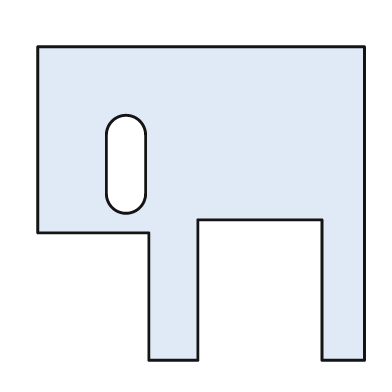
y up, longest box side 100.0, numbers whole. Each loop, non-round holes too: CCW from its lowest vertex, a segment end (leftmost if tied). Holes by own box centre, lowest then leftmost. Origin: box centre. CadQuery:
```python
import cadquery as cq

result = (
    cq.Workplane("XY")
    .moveTo(-16.0, -48.0)
    .lineTo(-1.0, -48.0)
    .lineTo(-1.0, -5.0)
    .lineTo(37.0, -5.0)
    .lineTo(37.0, -48.0)
    .lineTo(50.0, -48.0)
    .lineTo(50.0, 48.0)
    .lineTo(-50.0, 48.0)
    .lineTo(-50.0, -9.0)
    .lineTo(-16.0, -9.0)
    .close()
    .moveTo(-29.0, 3.0)
    .threePointArc((-23.0, -3.0), (-17.0, 3.0))
    .lineTo(-17.0, 21.0)
    .threePointArc((-23.0, 27.0), (-29.0, 21.0))
    .close()
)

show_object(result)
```